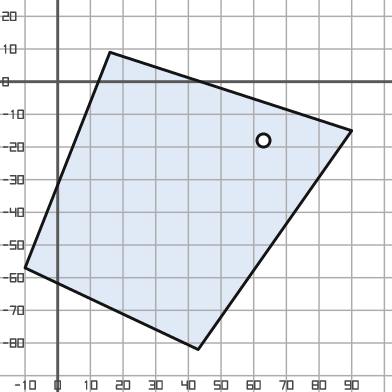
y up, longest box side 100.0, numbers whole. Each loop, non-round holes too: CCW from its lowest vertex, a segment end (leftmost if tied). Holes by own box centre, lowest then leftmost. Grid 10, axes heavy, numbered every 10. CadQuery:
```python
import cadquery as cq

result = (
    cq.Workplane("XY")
    .moveTo(43.0, -82.0)
    .lineTo(90.0, -15.0)
    .lineTo(16.0, 9.0)
    .lineTo(-10.0, -57.0)
    .close()
    .moveTo(63.0, -18.0)
    .circle(2.0)
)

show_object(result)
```